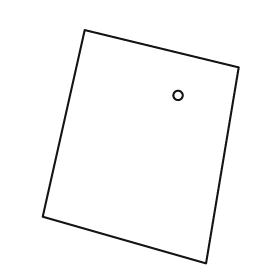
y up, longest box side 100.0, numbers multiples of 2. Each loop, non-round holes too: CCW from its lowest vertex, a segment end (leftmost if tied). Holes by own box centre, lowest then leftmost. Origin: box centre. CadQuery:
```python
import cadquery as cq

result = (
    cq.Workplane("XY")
    .moveTo(28.0, -50.0)
    .lineTo(42.0, 34.0)
    .lineTo(-24.0, 50.0)
    .lineTo(-42.0, -30.0)
    .close()
    .moveTo(16.0, 22.0)
    .circle(2.0)
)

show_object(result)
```